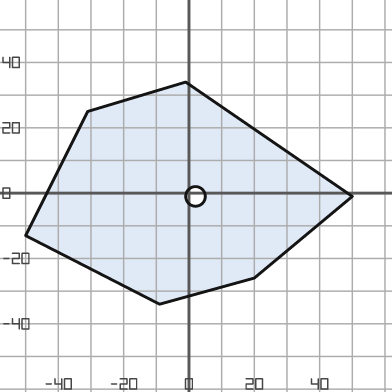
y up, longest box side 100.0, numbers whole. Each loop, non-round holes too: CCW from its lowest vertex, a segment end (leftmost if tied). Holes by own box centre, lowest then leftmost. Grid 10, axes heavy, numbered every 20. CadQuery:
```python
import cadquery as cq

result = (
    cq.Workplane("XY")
    .moveTo(-9.0, -34.0)
    .lineTo(20.0, -26.0)
    .lineTo(50.0, -1.0)
    .lineTo(-1.0, 34.0)
    .lineTo(-31.0, 25.0)
    .lineTo(-50.0, -13.0)
    .close()
    .moveTo(2.0, -1.0)
    .circle(3.0)
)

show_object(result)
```